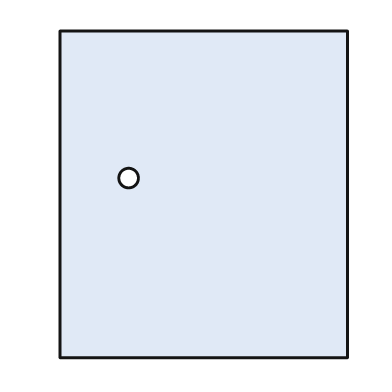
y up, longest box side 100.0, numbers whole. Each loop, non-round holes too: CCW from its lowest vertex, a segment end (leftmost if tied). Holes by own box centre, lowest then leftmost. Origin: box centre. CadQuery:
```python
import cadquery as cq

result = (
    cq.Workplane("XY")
    .moveTo(-44.0, -50.0)
    .lineTo(44.0, -50.0)
    .lineTo(44.0, 50.0)
    .lineTo(-44.0, 50.0)
    .close()
    .moveTo(-23.0, 5.0)
    .circle(3.0)
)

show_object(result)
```